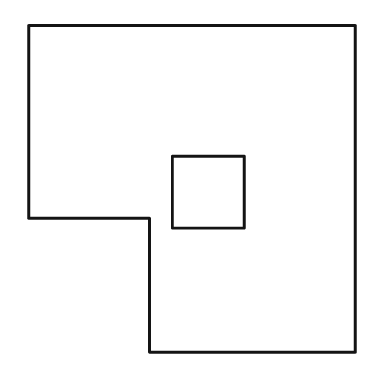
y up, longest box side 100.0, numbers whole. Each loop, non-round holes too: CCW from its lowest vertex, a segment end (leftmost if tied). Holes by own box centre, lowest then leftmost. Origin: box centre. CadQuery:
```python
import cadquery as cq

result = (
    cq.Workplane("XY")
    .moveTo(-13.0, -50.0)
    .lineTo(50.0, -50.0)
    .lineTo(50.0, 50.0)
    .lineTo(-50.0, 50.0)
    .lineTo(-50.0, -9.0)
    .lineTo(-13.0, -9.0)
    .close()
    .moveTo(-6.0, -12.0)
    .lineTo(16.0, -12.0)
    .lineTo(16.0, 10.0)
    .lineTo(-6.0, 10.0)
    .close()
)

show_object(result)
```